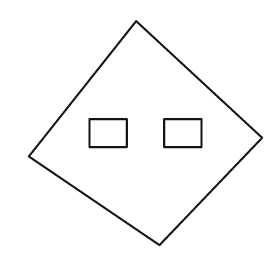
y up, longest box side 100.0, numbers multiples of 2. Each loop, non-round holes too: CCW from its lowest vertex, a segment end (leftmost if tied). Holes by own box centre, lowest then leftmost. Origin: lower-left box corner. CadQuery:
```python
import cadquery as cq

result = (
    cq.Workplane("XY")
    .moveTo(56.0, 0.0)
    .lineTo(100.0, 46.0)
    .lineTo(46.0, 96.0)
    .lineTo(0.0, 38.0)
    .close()
    .moveTo(26.0, 42.0)
    .lineTo(42.0, 42.0)
    .lineTo(42.0, 54.0)
    .lineTo(26.0, 54.0)
    .close()
    .moveTo(58.0, 42.0)
    .lineTo(74.0, 42.0)
    .lineTo(74.0, 54.0)
    .lineTo(58.0, 54.0)
    .close()
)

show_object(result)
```